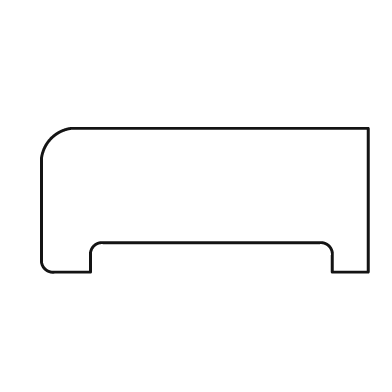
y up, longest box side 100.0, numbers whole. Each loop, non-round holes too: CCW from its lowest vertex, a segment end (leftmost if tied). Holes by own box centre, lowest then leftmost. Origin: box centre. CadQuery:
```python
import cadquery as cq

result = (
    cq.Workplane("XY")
    .moveTo(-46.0, -22.0)
    .lineTo(-35.0, -22.0)
    .lineTo(-35.0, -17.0)
    .threePointArc((-34.0, -14.0), (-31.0, -13.0))
    .lineTo(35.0, -13.0)
    .threePointArc((38.0, -14.0), (39.0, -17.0))
    .lineTo(39.0, -22.0)
    .lineTo(50.0, -22.0)
    .lineTo(50.0, 22.0)
    .lineTo(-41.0, 22.0)
    .threePointArc((-47.0, 19.0), (-50.0, 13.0))
    .lineTo(-50.0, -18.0)
    .threePointArc((-49.0, -21.0), (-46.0, -22.0))
    .close()
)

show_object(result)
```